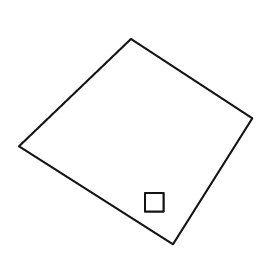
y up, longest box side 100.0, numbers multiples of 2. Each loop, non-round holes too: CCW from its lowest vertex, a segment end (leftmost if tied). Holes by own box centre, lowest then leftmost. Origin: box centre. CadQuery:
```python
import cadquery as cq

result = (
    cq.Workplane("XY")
    .moveTo(16.0, -44.0)
    .lineTo(50.0, 10.0)
    .lineTo(-2.0, 44.0)
    .lineTo(-50.0, -2.0)
    .close()
    .moveTo(4.0, -30.0)
    .lineTo(12.0, -30.0)
    .lineTo(12.0, -22.0)
    .lineTo(4.0, -22.0)
    .close()
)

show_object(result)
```